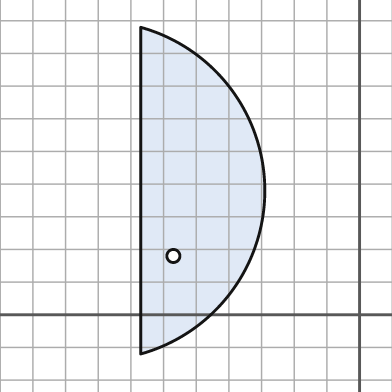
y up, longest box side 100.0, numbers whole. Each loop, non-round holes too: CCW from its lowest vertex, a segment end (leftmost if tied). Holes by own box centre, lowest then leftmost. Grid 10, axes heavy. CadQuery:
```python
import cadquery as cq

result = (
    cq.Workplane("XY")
    .moveTo(-67.0, -12.0)
    .threePointArc((-29.0, 38.0), (-67.0, 88.0))
    .close()
    .moveTo(-57.0, 18.0)
    .circle(2.0)
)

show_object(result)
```